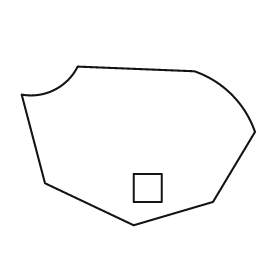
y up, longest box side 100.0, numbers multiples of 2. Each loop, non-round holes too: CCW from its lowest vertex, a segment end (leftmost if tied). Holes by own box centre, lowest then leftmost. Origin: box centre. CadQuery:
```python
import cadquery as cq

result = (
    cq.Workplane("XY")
    .moveTo(-2.0, -34.0)
    .lineTo(32.0, -24.0)
    .lineTo(50.0, 6.0)
    .threePointArc((40.0, 22.0), (24.0, 32.0))
    .lineTo(-26.0, 34.0)
    .threePointArc((-36.0, 24.0), (-50.0, 22.0))
    .lineTo(-40.0, -16.0)
    .close()
    .moveTo(-2.0, -24.0)
    .lineTo(10.0, -24.0)
    .lineTo(10.0, -12.0)
    .lineTo(-2.0, -12.0)
    .close()
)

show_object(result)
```